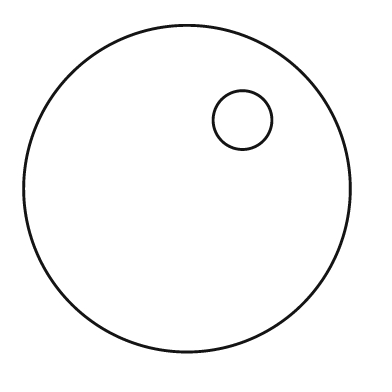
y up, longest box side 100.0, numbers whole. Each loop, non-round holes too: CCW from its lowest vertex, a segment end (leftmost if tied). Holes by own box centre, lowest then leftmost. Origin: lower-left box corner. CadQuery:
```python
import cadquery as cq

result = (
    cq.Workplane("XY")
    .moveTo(50.0, 50.0)
    .circle(50.0)
    .moveTo(67.0, 71.0)
    .circle(9.0)
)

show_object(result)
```